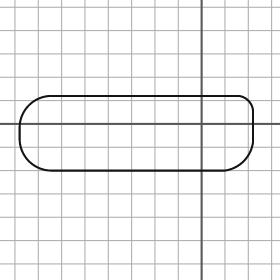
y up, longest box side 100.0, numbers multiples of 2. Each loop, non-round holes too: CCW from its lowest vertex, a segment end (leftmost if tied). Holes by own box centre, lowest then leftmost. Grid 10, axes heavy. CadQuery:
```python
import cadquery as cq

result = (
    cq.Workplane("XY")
    .moveTo(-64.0, -20.0)
    .lineTo(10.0, -20.0)
    .threePointArc((18.0, -16.0), (22.0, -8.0))
    .lineTo(22.0, 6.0)
    .threePointArc((20.0, 10.0), (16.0, 12.0))
    .lineTo(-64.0, 12.0)
    .threePointArc((-74.0, 8.0), (-78.0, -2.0))
    .lineTo(-78.0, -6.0)
    .threePointArc((-74.0, -16.0), (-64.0, -20.0))
    .close()
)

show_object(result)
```